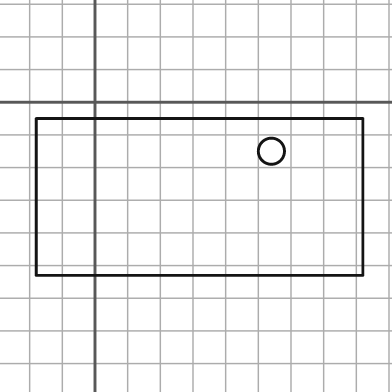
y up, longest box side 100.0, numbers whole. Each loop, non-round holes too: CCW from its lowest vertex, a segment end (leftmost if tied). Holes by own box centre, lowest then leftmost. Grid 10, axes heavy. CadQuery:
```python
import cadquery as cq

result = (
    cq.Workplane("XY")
    .moveTo(-18.0, -53.0)
    .lineTo(82.0, -53.0)
    .lineTo(82.0, -5.0)
    .lineTo(-18.0, -5.0)
    .close()
    .moveTo(54.0, -15.0)
    .circle(4.0)
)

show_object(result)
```